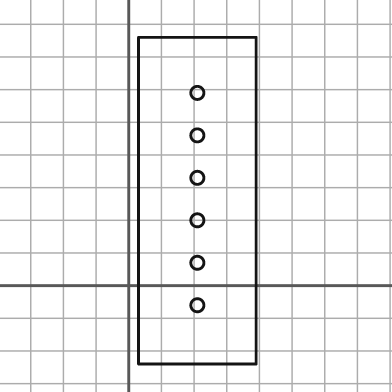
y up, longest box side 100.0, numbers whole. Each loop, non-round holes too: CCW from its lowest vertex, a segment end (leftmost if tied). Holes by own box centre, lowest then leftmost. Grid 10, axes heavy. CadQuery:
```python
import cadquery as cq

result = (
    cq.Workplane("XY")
    .moveTo(3.0, -24.0)
    .lineTo(39.0, -24.0)
    .lineTo(39.0, 76.0)
    .lineTo(3.0, 76.0)
    .close()
    .moveTo(21.0, -6.0)
    .circle(2.0)
    .moveTo(21.0, 7.0)
    .circle(2.0)
    .moveTo(21.0, 20.0)
    .circle(2.0)
    .moveTo(21.0, 33.0)
    .circle(2.0)
    .moveTo(21.0, 46.0)
    .circle(2.0)
    .moveTo(21.0, 59.0)
    .circle(2.0)
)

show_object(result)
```